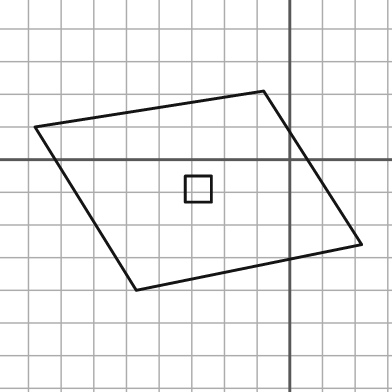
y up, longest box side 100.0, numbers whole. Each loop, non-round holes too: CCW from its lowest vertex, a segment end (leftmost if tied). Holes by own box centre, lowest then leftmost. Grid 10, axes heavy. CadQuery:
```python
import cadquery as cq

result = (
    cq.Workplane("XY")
    .moveTo(-47.0, -40.0)
    .lineTo(22.0, -26.0)
    .lineTo(-8.0, 21.0)
    .lineTo(-78.0, 10.0)
    .close()
    .moveTo(-32.0, -13.0)
    .lineTo(-24.0, -13.0)
    .lineTo(-24.0, -5.0)
    .lineTo(-32.0, -5.0)
    .close()
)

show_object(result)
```